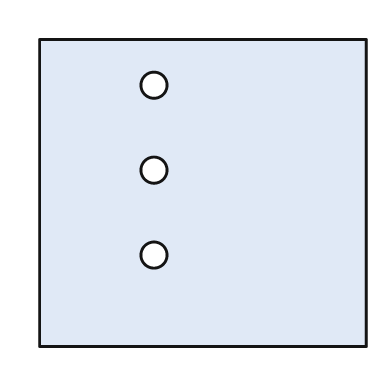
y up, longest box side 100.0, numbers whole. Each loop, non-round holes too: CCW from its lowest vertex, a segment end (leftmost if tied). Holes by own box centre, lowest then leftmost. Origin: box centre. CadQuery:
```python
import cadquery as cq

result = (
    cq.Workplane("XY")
    .moveTo(-50.0, -47.0)
    .lineTo(50.0, -47.0)
    .lineTo(50.0, 47.0)
    .lineTo(-50.0, 47.0)
    .close()
    .moveTo(-15.0, -19.0)
    .circle(4.0)
    .moveTo(-15.0, 7.0)
    .circle(4.0)
    .moveTo(-15.0, 33.0)
    .circle(4.0)
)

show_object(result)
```